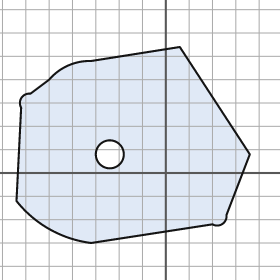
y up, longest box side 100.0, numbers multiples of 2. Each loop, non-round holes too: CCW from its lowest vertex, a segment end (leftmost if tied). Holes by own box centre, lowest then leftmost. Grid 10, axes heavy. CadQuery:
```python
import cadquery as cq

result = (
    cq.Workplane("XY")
    .moveTo(-32.0, -30.0)
    .lineTo(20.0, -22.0)
    .threePointArc((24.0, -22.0), (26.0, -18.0))
    .lineTo(36.0, 8.0)
    .lineTo(6.0, 54.0)
    .lineTo(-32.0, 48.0)
    .threePointArc((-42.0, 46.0), (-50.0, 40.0))
    .lineTo(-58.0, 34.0)
    .threePointArc((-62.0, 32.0), (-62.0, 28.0))
    .lineTo(-64.0, -12.0)
    .threePointArc((-50.0, -24.0), (-32.0, -30.0))
    .close()
    .moveTo(-24.0, 8.0)
    .circle(6.0)
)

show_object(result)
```